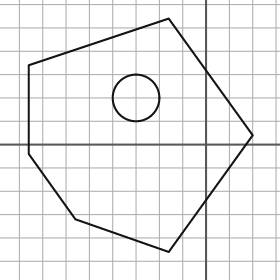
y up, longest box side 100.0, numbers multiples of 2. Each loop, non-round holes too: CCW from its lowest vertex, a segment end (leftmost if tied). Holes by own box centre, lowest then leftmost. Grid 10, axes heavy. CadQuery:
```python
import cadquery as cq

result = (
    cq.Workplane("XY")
    .moveTo(-16.0, -46.0)
    .lineTo(20.0, 4.0)
    .lineTo(-16.0, 54.0)
    .lineTo(-76.0, 34.0)
    .lineTo(-76.0, -4.0)
    .lineTo(-56.0, -32.0)
    .close()
    .moveTo(-30.0, 20.0)
    .circle(10.0)
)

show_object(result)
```